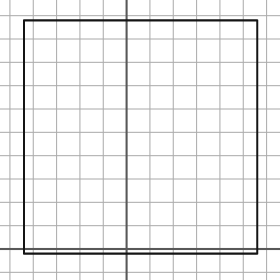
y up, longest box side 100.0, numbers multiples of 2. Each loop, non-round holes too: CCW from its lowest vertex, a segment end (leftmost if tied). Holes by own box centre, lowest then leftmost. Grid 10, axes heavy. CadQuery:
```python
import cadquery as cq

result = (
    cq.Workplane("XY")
    .moveTo(-44.0, -2.0)
    .lineTo(56.0, -2.0)
    .lineTo(56.0, 98.0)
    .lineTo(-44.0, 98.0)
    .close()
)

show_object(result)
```